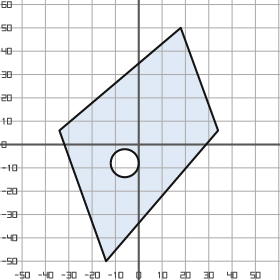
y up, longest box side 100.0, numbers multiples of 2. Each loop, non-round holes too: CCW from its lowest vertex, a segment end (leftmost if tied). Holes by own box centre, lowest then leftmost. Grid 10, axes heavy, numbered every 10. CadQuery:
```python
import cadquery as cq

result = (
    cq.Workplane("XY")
    .moveTo(-14.0, -50.0)
    .lineTo(34.0, 6.0)
    .lineTo(18.0, 50.0)
    .lineTo(-34.0, 6.0)
    .close()
    .moveTo(-6.0, -8.0)
    .circle(6.0)
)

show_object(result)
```